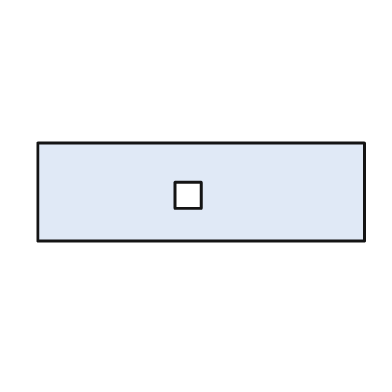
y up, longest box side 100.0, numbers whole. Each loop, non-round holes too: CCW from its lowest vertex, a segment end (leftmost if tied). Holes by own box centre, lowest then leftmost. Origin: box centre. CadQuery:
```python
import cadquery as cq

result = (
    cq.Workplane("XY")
    .moveTo(-50.0, -15.0)
    .lineTo(50.0, -15.0)
    .lineTo(50.0, 15.0)
    .lineTo(-50.0, 15.0)
    .close()
    .moveTo(-8.0, -5.0)
    .lineTo(0.0, -5.0)
    .lineTo(0.0, 3.0)
    .lineTo(-8.0, 3.0)
    .close()
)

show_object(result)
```